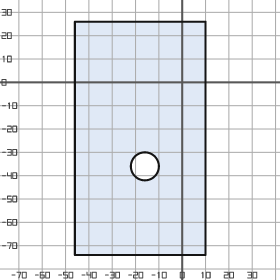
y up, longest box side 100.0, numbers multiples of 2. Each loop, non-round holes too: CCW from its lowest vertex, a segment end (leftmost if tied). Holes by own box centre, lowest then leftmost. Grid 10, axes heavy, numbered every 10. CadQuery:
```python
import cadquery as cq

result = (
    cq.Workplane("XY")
    .moveTo(-46.0, -74.0)
    .lineTo(10.0, -74.0)
    .lineTo(10.0, 26.0)
    .lineTo(-46.0, 26.0)
    .close()
    .moveTo(-16.0, -36.0)
    .circle(6.0)
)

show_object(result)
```